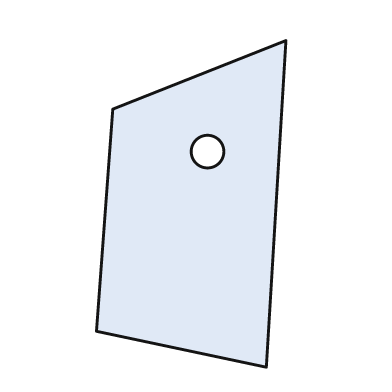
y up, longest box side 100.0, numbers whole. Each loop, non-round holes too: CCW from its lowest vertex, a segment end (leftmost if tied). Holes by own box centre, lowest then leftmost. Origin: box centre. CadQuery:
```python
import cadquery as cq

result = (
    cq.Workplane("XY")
    .moveTo(23.0, -50.0)
    .lineTo(29.0, 50.0)
    .lineTo(-24.0, 29.0)
    .lineTo(-29.0, -39.0)
    .close()
    .moveTo(5.0, 16.0)
    .circle(5.0)
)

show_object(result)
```